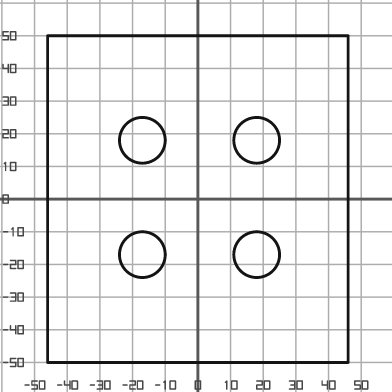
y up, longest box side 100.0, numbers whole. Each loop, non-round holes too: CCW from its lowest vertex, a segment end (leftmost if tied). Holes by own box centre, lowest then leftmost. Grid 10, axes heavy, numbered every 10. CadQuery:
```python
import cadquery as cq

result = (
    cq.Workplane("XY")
    .moveTo(-46.0, -50.0)
    .lineTo(46.0, -50.0)
    .lineTo(46.0, 50.0)
    .lineTo(-46.0, 50.0)
    .close()
    .moveTo(-17.0, -17.0)
    .circle(7.0)
    .moveTo(18.0, -17.0)
    .circle(7.0)
    .moveTo(-17.0, 18.0)
    .circle(7.0)
    .moveTo(18.0, 18.0)
    .circle(7.0)
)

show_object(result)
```